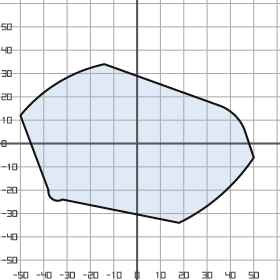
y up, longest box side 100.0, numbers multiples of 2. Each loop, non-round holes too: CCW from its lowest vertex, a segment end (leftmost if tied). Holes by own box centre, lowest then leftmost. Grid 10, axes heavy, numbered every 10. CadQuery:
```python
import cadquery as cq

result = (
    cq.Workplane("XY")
    .moveTo(18.0, -34.0)
    .threePointArc((36.0, -22.0), (50.0, -6.0))
    .lineTo(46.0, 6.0)
    .threePointArc((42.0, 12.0), (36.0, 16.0))
    .lineTo(-14.0, 34.0)
    .threePointArc((-34.0, 26.0), (-50.0, 12.0))
    .lineTo(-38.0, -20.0)
    .threePointArc((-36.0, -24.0), (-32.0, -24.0))
    .close()
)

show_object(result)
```